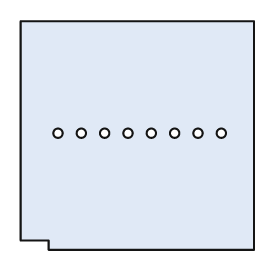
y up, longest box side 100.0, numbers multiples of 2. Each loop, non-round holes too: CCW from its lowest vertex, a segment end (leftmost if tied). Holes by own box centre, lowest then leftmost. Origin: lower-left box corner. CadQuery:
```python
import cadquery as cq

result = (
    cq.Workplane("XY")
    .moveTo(12.0, 0.0)
    .lineTo(100.0, 0.0)
    .lineTo(100.0, 98.0)
    .lineTo(0.0, 98.0)
    .lineTo(0.0, 4.0)
    .lineTo(12.0, 4.0)
    .close()
    .moveTo(16.0, 50.0)
    .circle(2.0)
    .moveTo(26.0, 50.0)
    .circle(2.0)
    .moveTo(36.0, 50.0)
    .circle(2.0)
    .moveTo(46.0, 50.0)
    .circle(2.0)
    .moveTo(56.0, 50.0)
    .circle(2.0)
    .moveTo(66.0, 50.0)
    .circle(2.0)
    .moveTo(76.0, 50.0)
    .circle(2.0)
    .moveTo(86.0, 50.0)
    .circle(2.0)
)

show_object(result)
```